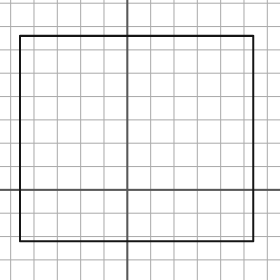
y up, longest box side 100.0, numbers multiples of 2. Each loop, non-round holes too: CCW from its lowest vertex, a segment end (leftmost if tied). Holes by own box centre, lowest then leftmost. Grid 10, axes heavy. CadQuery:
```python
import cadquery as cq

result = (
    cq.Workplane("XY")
    .moveTo(-46.0, -22.0)
    .lineTo(54.0, -22.0)
    .lineTo(54.0, 66.0)
    .lineTo(-46.0, 66.0)
    .close()
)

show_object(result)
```